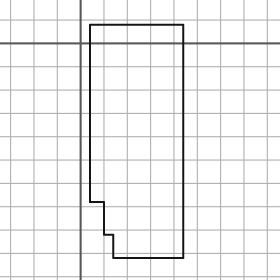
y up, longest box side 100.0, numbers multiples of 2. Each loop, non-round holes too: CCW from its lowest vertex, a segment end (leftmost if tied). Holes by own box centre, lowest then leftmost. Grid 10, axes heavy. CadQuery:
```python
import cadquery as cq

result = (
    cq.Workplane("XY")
    .moveTo(14.0, -92.0)
    .lineTo(44.0, -92.0)
    .lineTo(44.0, 8.0)
    .lineTo(4.0, 8.0)
    .lineTo(4.0, -68.0)
    .lineTo(10.0, -68.0)
    .lineTo(10.0, -82.0)
    .lineTo(14.0, -82.0)
    .close()
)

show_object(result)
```